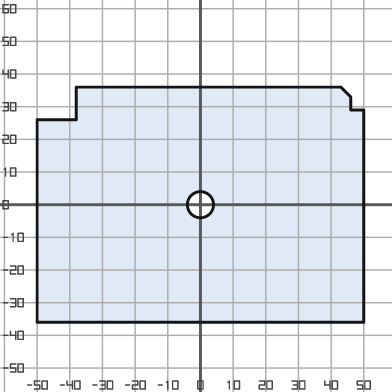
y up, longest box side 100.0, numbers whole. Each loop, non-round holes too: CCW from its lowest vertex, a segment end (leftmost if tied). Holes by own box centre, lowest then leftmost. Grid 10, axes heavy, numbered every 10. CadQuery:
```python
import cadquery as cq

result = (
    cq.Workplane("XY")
    .moveTo(-50.0, -36.0)
    .lineTo(50.0, -36.0)
    .lineTo(50.0, 29.0)
    .lineTo(46.0, 29.0)
    .lineTo(46.0, 33.0)
    .lineTo(43.0, 36.0)
    .lineTo(-38.0, 36.0)
    .lineTo(-38.0, 26.0)
    .lineTo(-50.0, 26.0)
    .close()
    .moveTo(0.0, 0.0)
    .circle(4.0)
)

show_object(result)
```